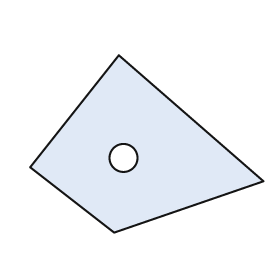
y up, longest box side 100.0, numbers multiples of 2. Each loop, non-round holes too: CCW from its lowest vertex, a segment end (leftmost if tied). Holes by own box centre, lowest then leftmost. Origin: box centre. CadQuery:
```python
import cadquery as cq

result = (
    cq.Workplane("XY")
    .moveTo(-14.0, -38.0)
    .lineTo(50.0, -16.0)
    .lineTo(-12.0, 38.0)
    .lineTo(-50.0, -10.0)
    .close()
    .moveTo(-10.0, -6.0)
    .circle(6.0)
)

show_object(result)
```